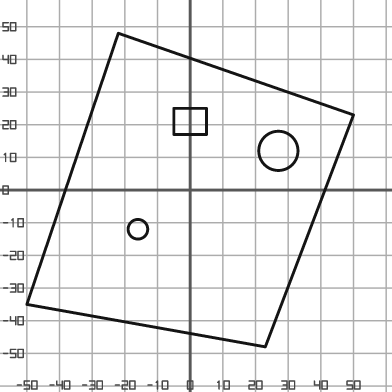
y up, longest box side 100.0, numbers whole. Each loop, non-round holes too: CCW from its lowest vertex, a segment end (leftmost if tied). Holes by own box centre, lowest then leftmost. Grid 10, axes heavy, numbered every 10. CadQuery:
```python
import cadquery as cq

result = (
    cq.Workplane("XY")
    .moveTo(23.0, -48.0)
    .lineTo(50.0, 23.0)
    .lineTo(-22.0, 48.0)
    .lineTo(-50.0, -35.0)
    .close()
    .moveTo(-16.0, -12.0)
    .circle(3.0)
    .moveTo(27.0, 12.0)
    .circle(6.0)
    .moveTo(-5.0, 17.0)
    .lineTo(5.0, 17.0)
    .lineTo(5.0, 25.0)
    .lineTo(-5.0, 25.0)
    .close()
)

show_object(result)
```